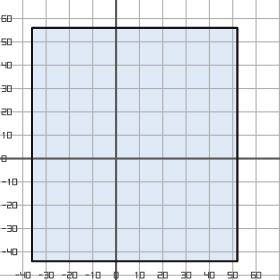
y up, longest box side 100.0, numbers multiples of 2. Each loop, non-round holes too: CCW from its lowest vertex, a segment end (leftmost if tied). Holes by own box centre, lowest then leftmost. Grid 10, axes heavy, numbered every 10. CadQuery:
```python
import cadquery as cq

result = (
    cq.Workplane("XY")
    .moveTo(-36.0, -44.0)
    .lineTo(52.0, -44.0)
    .lineTo(52.0, 56.0)
    .lineTo(-36.0, 56.0)
    .close()
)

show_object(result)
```